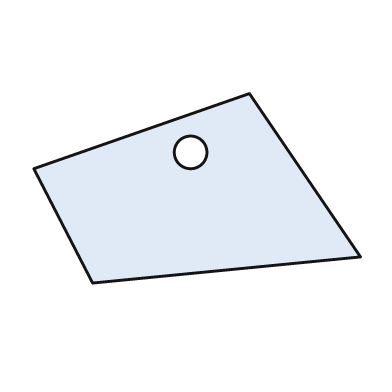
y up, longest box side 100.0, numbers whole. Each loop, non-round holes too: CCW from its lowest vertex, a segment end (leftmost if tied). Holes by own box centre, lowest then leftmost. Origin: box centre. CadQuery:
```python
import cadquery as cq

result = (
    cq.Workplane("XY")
    .moveTo(-32.0, -29.0)
    .lineTo(50.0, -21.0)
    .lineTo(16.0, 29.0)
    .lineTo(-50.0, 6.0)
    .close()
    .moveTo(-2.0, 11.0)
    .circle(5.0)
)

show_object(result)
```